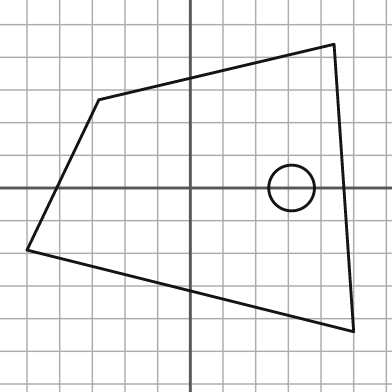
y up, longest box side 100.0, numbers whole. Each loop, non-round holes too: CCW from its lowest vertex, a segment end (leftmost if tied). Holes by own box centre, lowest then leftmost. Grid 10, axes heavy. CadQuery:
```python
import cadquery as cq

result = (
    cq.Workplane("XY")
    .moveTo(50.0, -44.0)
    .lineTo(44.0, 44.0)
    .lineTo(-28.0, 27.0)
    .lineTo(-50.0, -19.0)
    .close()
    .moveTo(31.0, 0.0)
    .circle(7.0)
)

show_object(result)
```